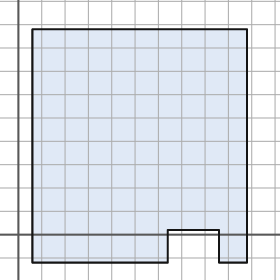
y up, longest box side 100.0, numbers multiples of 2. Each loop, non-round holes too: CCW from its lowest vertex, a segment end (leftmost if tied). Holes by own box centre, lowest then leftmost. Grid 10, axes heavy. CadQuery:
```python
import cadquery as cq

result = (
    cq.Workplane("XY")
    .moveTo(6.0, -12.0)
    .lineTo(64.0, -12.0)
    .lineTo(64.0, 2.0)
    .lineTo(86.0, 2.0)
    .lineTo(86.0, -12.0)
    .lineTo(98.0, -12.0)
    .lineTo(98.0, 88.0)
    .lineTo(6.0, 88.0)
    .close()
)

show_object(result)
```